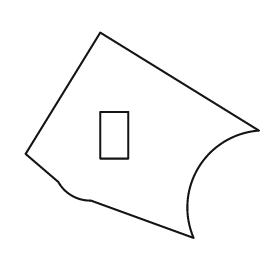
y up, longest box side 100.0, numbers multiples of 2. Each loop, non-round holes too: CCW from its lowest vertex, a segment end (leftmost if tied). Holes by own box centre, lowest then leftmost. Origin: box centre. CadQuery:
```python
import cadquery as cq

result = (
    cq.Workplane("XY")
    .moveTo(22.0, -44.0)
    .threePointArc((24.0, -14.0), (50.0, 2.0))
    .lineTo(-18.0, 44.0)
    .lineTo(-50.0, -8.0)
    .lineTo(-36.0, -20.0)
    .threePointArc((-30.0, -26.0), (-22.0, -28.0))
    .close()
    .moveTo(-18.0, -10.0)
    .lineTo(-6.0, -10.0)
    .lineTo(-6.0, 10.0)
    .lineTo(-18.0, 10.0)
    .close()
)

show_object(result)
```